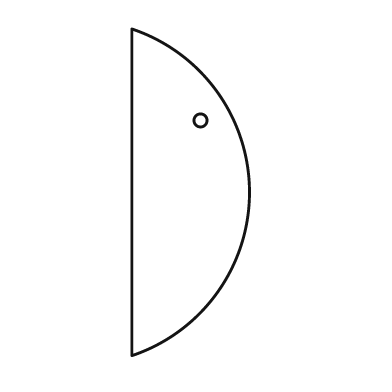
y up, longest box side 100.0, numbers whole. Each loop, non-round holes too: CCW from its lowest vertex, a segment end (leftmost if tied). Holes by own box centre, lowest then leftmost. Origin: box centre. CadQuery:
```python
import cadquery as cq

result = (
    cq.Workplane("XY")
    .moveTo(-18.0, -50.0)
    .threePointArc((18.0, 0.0), (-18.0, 50.0))
    .close()
    .moveTo(3.0, 22.0)
    .circle(2.0)
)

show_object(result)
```